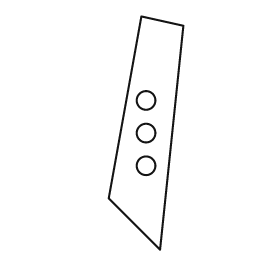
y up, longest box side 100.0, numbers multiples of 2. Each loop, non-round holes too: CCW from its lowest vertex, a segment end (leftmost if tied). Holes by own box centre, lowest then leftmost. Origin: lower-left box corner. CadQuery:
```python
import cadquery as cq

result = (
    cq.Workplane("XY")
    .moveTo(22.0, 0.0)
    .lineTo(32.0, 96.0)
    .lineTo(14.0, 100.0)
    .lineTo(0.0, 22.0)
    .close()
    .moveTo(16.0, 36.0)
    .circle(4.0)
    .moveTo(16.0, 50.0)
    .circle(4.0)
    .moveTo(16.0, 64.0)
    .circle(4.0)
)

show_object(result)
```